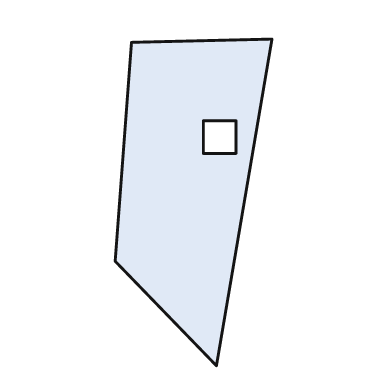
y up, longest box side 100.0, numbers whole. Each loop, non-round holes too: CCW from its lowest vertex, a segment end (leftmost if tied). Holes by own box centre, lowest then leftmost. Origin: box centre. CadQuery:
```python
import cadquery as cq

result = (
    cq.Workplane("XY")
    .moveTo(7.0, -50.0)
    .lineTo(24.0, 50.0)
    .lineTo(-19.0, 49.0)
    .lineTo(-24.0, -18.0)
    .close()
    .moveTo(3.0, 15.0)
    .lineTo(13.0, 15.0)
    .lineTo(13.0, 25.0)
    .lineTo(3.0, 25.0)
    .close()
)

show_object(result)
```